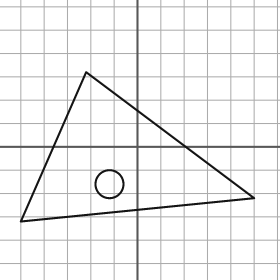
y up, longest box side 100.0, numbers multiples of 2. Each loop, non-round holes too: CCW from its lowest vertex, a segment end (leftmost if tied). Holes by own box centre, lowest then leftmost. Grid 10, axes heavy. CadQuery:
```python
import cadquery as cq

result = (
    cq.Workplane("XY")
    .moveTo(-50.0, -32.0)
    .lineTo(50.0, -22.0)
    .lineTo(-22.0, 32.0)
    .close()
    .moveTo(-12.0, -16.0)
    .circle(6.0)
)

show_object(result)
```